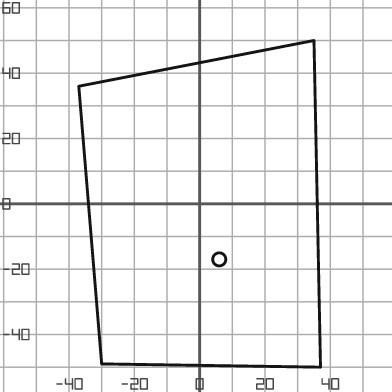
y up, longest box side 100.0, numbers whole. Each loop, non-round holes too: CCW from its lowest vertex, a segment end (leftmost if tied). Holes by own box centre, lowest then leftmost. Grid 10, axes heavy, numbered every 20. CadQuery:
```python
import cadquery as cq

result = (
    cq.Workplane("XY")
    .moveTo(37.0, -50.0)
    .lineTo(35.0, 50.0)
    .lineTo(-37.0, 36.0)
    .lineTo(-30.0, -49.0)
    .close()
    .moveTo(6.0, -17.0)
    .circle(2.0)
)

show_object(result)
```